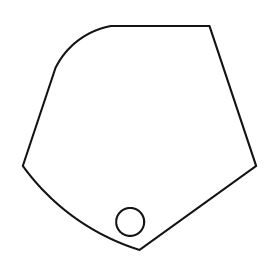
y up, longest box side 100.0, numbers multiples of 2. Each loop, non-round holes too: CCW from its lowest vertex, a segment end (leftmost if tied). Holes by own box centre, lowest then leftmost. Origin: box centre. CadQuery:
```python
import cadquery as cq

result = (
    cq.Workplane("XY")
    .moveTo(0.0, -48.0)
    .lineTo(50.0, -12.0)
    .lineTo(30.0, 48.0)
    .lineTo(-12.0, 48.0)
    .threePointArc((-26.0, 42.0), (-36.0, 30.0))
    .lineTo(-50.0, -12.0)
    .threePointArc((-28.0, -34.0), (0.0, -48.0))
    .close()
    .moveTo(-4.0, -36.0)
    .circle(6.0)
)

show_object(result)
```